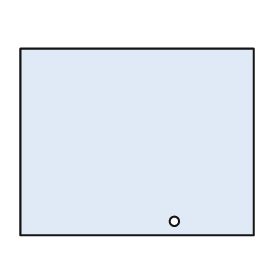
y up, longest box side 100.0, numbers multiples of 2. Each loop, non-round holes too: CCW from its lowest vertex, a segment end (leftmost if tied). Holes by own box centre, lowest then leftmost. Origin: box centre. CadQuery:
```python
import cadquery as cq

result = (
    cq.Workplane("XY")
    .moveTo(-50.0, -40.0)
    .lineTo(50.0, -40.0)
    .lineTo(50.0, 40.0)
    .lineTo(-50.0, 40.0)
    .close()
    .moveTo(16.0, -34.0)
    .circle(2.0)
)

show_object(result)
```